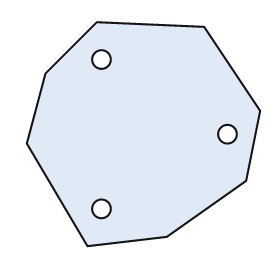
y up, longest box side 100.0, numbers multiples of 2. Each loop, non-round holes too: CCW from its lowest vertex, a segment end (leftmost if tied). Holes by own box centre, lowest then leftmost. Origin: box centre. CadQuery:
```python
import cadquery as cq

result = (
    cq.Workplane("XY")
    .moveTo(-24.0, -48.0)
    .lineTo(10.0, -44.0)
    .lineTo(44.0, -20.0)
    .lineTo(50.0, 10.0)
    .lineTo(26.0, 46.0)
    .lineTo(-20.0, 48.0)
    .lineTo(-42.0, 26.0)
    .lineTo(-50.0, -4.0)
    .close()
    .moveTo(-18.0, -32.0)
    .circle(4.0)
    .moveTo(36.0, 0.0)
    .circle(4.0)
    .moveTo(-18.0, 32.0)
    .circle(4.0)
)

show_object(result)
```